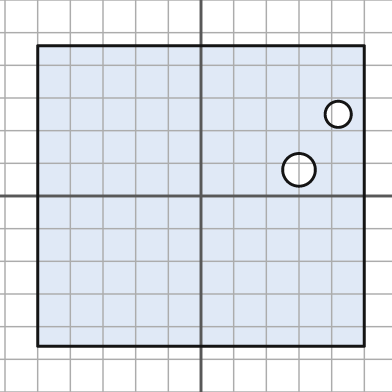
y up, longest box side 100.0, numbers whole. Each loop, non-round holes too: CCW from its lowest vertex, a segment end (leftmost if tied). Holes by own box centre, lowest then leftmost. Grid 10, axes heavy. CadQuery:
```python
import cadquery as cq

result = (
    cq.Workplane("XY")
    .moveTo(-50.0, -46.0)
    .lineTo(50.0, -46.0)
    .lineTo(50.0, 46.0)
    .lineTo(-50.0, 46.0)
    .close()
    .moveTo(30.0, 8.0)
    .circle(5.0)
    .moveTo(42.0, 25.0)
    .circle(4.0)
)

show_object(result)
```